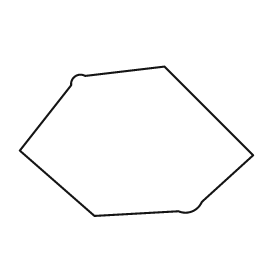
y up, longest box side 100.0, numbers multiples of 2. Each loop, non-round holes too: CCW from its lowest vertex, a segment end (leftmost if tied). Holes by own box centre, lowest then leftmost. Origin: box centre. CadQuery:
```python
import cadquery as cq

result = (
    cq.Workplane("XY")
    .moveTo(-18.0, -32.0)
    .lineTo(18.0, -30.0)
    .threePointArc((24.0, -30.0), (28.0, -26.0))
    .lineTo(50.0, -6.0)
    .lineTo(12.0, 32.0)
    .lineTo(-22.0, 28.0)
    .threePointArc((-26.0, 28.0), (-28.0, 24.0))
    .lineTo(-50.0, -4.0)
    .close()
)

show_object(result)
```